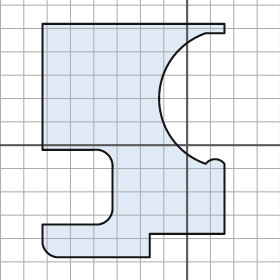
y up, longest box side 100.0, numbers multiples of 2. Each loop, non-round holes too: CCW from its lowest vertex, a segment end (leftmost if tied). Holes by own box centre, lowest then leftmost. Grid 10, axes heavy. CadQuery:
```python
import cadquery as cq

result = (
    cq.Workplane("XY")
    .moveTo(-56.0, -48.0)
    .lineTo(-16.0, -48.0)
    .lineTo(-16.0, -38.0)
    .lineTo(16.0, -38.0)
    .lineTo(16.0, -8.0)
    .threePointArc((12.0, -6.0), (8.0, -8.0))
    .threePointArc((-12.0, 20.0), (8.0, 48.0))
    .lineTo(16.0, 48.0)
    .lineTo(16.0, 52.0)
    .lineTo(-62.0, 52.0)
    .lineTo(-62.0, -2.0)
    .lineTo(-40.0, -2.0)
    .threePointArc((-34.0, -4.0), (-32.0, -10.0))
    .lineTo(-32.0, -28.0)
    .threePointArc((-34.0, -32.0), (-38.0, -34.0))
    .lineTo(-62.0, -34.0)
    .lineTo(-62.0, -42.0)
    .threePointArc((-60.0, -46.0), (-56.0, -48.0))
    .close()
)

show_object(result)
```